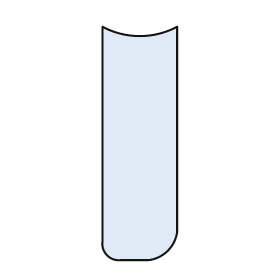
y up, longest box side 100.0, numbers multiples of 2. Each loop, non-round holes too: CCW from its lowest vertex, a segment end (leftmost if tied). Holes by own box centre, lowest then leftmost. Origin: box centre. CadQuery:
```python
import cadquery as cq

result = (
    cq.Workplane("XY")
    .moveTo(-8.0, -50.0)
    .lineTo(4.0, -50.0)
    .threePointArc((12.0, -46.0), (16.0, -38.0))
    .lineTo(16.0, 50.0)
    .threePointArc((0.0, 46.0), (-16.0, 50.0))
    .lineTo(-16.0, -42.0)
    .threePointArc((-14.0, -48.0), (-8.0, -50.0))
    .close()
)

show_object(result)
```